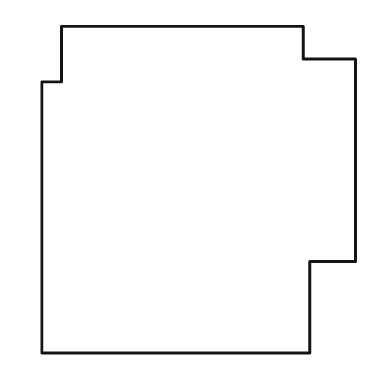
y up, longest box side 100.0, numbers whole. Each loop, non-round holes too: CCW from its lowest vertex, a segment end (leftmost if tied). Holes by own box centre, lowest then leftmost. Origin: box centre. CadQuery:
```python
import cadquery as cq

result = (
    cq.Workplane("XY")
    .moveTo(-48.0, -50.0)
    .lineTo(34.0, -50.0)
    .lineTo(34.0, -22.0)
    .lineTo(48.0, -22.0)
    .lineTo(48.0, 40.0)
    .lineTo(32.0, 40.0)
    .lineTo(32.0, 50.0)
    .lineTo(-42.0, 50.0)
    .lineTo(-42.0, 33.0)
    .lineTo(-48.0, 33.0)
    .close()
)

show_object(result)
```